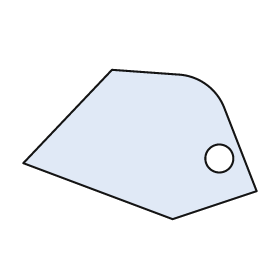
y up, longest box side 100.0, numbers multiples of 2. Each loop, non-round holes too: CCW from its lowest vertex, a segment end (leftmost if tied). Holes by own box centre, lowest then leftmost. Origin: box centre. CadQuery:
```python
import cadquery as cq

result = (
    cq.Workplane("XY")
    .moveTo(14.0, -32.0)
    .lineTo(50.0, -20.0)
    .lineTo(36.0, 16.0)
    .threePointArc((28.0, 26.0), (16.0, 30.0))
    .lineTo(-12.0, 32.0)
    .lineTo(-50.0, -8.0)
    .close()
    .moveTo(34.0, -6.0)
    .circle(6.0)
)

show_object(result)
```